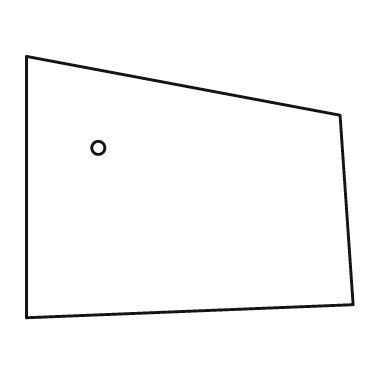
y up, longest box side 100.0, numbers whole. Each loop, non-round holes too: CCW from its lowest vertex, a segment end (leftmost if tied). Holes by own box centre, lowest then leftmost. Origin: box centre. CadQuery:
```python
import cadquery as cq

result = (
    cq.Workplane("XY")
    .moveTo(-50.0, -40.0)
    .lineTo(50.0, -36.0)
    .lineTo(46.0, 22.0)
    .lineTo(-50.0, 40.0)
    .close()
    .moveTo(-28.0, 12.0)
    .circle(2.0)
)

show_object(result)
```